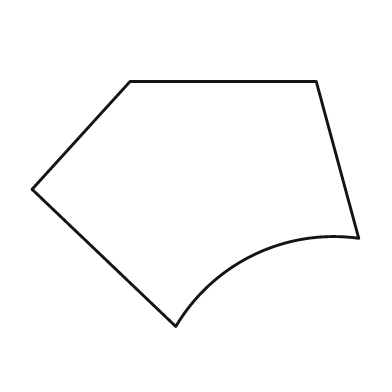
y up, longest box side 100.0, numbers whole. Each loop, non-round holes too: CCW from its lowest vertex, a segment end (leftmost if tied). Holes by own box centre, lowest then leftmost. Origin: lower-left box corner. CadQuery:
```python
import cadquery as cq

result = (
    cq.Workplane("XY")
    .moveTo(44.0, 0.0)
    .threePointArc((68.0, 22.0), (100.0, 27.0))
    .lineTo(87.0, 75.0)
    .lineTo(30.0, 75.0)
    .lineTo(0.0, 42.0)
    .close()
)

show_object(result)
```